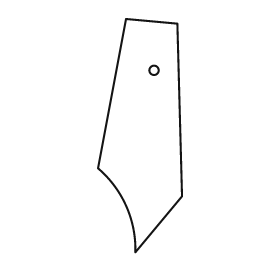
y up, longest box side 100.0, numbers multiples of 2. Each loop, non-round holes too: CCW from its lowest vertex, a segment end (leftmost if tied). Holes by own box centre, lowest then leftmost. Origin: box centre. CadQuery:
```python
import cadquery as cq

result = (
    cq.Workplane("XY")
    .moveTo(-2.0, -50.0)
    .lineTo(18.0, -26.0)
    .lineTo(16.0, 48.0)
    .lineTo(-6.0, 50.0)
    .lineTo(-18.0, -14.0)
    .threePointArc((-6.0, -30.0), (-2.0, -50.0))
    .close()
    .moveTo(6.0, 28.0)
    .circle(2.0)
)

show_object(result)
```